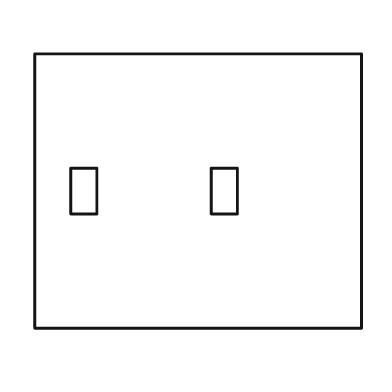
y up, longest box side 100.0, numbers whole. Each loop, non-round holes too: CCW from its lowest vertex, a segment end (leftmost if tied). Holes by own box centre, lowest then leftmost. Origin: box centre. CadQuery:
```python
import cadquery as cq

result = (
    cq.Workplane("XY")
    .moveTo(-50.0, -42.0)
    .lineTo(50.0, -42.0)
    .lineTo(50.0, 42.0)
    .lineTo(-50.0, 42.0)
    .close()
    .moveTo(-39.0, -7.0)
    .lineTo(-31.0, -7.0)
    .lineTo(-31.0, 7.0)
    .lineTo(-39.0, 7.0)
    .close()
    .moveTo(4.0, -7.0)
    .lineTo(12.0, -7.0)
    .lineTo(12.0, 7.0)
    .lineTo(4.0, 7.0)
    .close()
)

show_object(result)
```